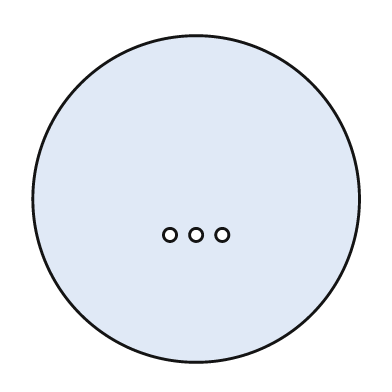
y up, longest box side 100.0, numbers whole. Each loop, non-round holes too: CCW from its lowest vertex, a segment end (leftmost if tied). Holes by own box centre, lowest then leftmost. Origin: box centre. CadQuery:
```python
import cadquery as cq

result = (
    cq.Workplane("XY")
    .moveTo(0.0, 0.0)
    .circle(50.0)
    .moveTo(-8.0, -11.0)
    .circle(2.0)
    .moveTo(0.0, -11.0)
    .circle(2.0)
    .moveTo(8.0, -11.0)
    .circle(2.0)
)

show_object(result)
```